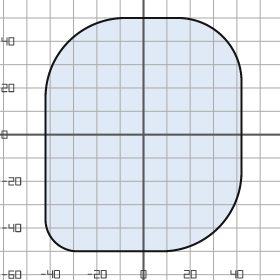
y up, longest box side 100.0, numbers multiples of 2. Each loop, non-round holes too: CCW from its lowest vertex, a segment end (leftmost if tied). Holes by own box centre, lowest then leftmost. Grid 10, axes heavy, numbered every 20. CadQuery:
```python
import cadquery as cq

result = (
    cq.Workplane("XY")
    .moveTo(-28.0, -50.0)
    .lineTo(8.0, -50.0)
    .threePointArc((32.0, -40.0), (42.0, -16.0))
    .lineTo(42.0, 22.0)
    .threePointArc((34.0, 42.0), (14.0, 50.0))
    .lineTo(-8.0, 50.0)
    .threePointArc((-32.0, 40.0), (-42.0, 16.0))
    .lineTo(-42.0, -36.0)
    .threePointArc((-38.0, -46.0), (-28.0, -50.0))
    .close()
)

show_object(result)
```